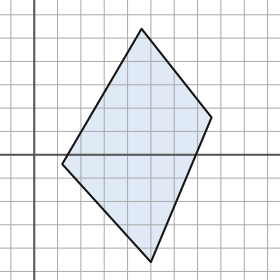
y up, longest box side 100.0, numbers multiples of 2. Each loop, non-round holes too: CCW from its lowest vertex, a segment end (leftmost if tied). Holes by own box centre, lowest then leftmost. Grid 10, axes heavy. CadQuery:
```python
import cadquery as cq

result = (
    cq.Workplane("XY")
    .moveTo(50.0, -46.0)
    .lineTo(76.0, 16.0)
    .lineTo(46.0, 54.0)
    .lineTo(12.0, -4.0)
    .close()
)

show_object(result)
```